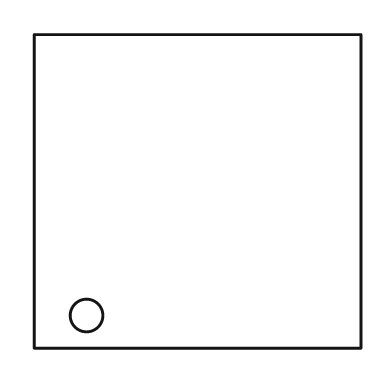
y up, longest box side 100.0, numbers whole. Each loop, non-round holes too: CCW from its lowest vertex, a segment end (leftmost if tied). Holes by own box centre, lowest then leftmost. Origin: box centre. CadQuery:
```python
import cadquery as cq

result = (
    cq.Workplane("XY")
    .moveTo(-50.0, -48.0)
    .lineTo(50.0, -48.0)
    .lineTo(50.0, 48.0)
    .lineTo(-50.0, 48.0)
    .close()
    .moveTo(-34.0, -38.0)
    .circle(5.0)
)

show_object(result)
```